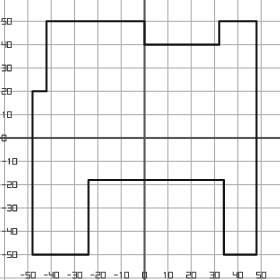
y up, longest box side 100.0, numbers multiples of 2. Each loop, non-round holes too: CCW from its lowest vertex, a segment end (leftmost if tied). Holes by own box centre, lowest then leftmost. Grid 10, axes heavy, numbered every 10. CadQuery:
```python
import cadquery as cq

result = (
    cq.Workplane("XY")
    .moveTo(-48.0, -50.0)
    .lineTo(-24.0, -50.0)
    .lineTo(-24.0, -18.0)
    .lineTo(34.0, -18.0)
    .lineTo(34.0, -50.0)
    .lineTo(48.0, -50.0)
    .lineTo(48.0, 50.0)
    .lineTo(32.0, 50.0)
    .lineTo(32.0, 40.0)
    .lineTo(0.0, 40.0)
    .lineTo(0.0, 50.0)
    .lineTo(-42.0, 50.0)
    .lineTo(-42.0, 20.0)
    .lineTo(-48.0, 20.0)
    .close()
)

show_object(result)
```